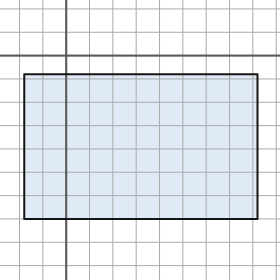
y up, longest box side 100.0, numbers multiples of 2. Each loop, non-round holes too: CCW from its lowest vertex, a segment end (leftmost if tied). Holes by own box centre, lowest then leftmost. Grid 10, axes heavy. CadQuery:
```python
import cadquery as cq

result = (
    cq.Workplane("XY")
    .moveTo(-18.0, -70.0)
    .lineTo(82.0, -70.0)
    .lineTo(82.0, -8.0)
    .lineTo(-18.0, -8.0)
    .close()
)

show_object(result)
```